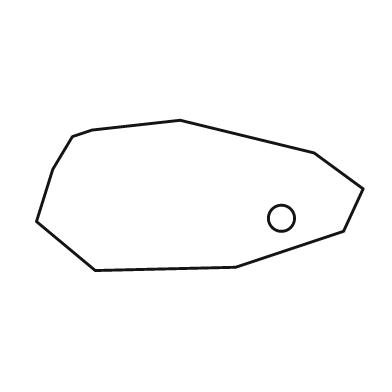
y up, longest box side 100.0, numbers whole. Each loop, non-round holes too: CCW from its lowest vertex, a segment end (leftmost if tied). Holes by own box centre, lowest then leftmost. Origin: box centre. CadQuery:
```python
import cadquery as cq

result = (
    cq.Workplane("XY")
    .moveTo(-32.0, -23.0)
    .lineTo(11.0, -22.0)
    .lineTo(44.0, -11.0)
    .lineTo(50.0, 2.0)
    .lineTo(35.0, 13.0)
    .lineTo(-6.0, 23.0)
    .lineTo(-33.0, 20.0)
    .lineTo(-39.0, 18.0)
    .lineTo(-45.0, 8.0)
    .lineTo(-50.0, -8.0)
    .close()
    .moveTo(25.0, -7.0)
    .circle(4.0)
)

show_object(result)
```